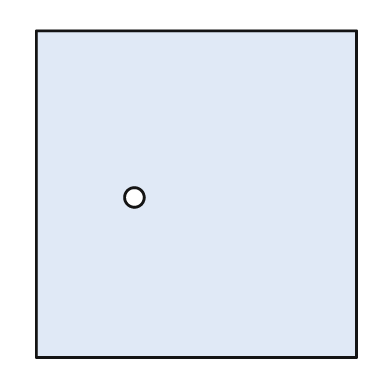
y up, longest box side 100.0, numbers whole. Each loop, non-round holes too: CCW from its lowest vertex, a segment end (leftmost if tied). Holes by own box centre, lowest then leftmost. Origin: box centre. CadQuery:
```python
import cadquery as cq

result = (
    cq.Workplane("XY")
    .moveTo(-49.0, -50.0)
    .lineTo(49.0, -50.0)
    .lineTo(49.0, 50.0)
    .lineTo(-49.0, 50.0)
    .close()
    .moveTo(-19.0, -1.0)
    .circle(3.0)
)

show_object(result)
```